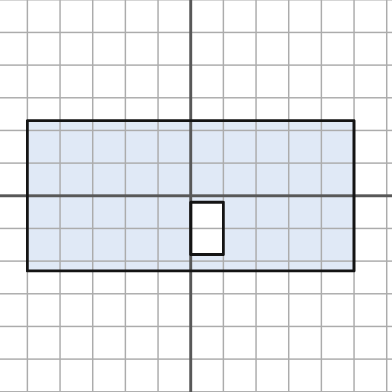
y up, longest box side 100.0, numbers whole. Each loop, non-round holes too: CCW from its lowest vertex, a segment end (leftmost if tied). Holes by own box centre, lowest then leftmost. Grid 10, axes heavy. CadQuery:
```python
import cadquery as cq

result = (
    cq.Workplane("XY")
    .moveTo(-50.0, -23.0)
    .lineTo(50.0, -23.0)
    .lineTo(50.0, 23.0)
    .lineTo(-50.0, 23.0)
    .close()
    .moveTo(0.0, -18.0)
    .lineTo(10.0, -18.0)
    .lineTo(10.0, -2.0)
    .lineTo(0.0, -2.0)
    .close()
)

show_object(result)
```